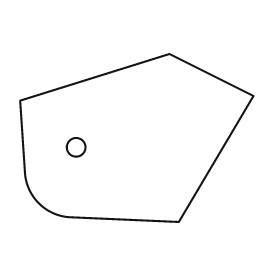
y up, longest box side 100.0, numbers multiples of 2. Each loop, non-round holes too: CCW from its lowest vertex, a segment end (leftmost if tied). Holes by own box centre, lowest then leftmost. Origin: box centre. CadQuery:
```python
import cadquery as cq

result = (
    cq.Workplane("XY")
    .moveTo(18.0, -36.0)
    .lineTo(50.0, 18.0)
    .lineTo(14.0, 36.0)
    .lineTo(-50.0, 16.0)
    .lineTo(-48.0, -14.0)
    .threePointArc((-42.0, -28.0), (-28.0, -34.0))
    .close()
    .moveTo(-26.0, -4.0)
    .circle(4.0)
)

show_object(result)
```